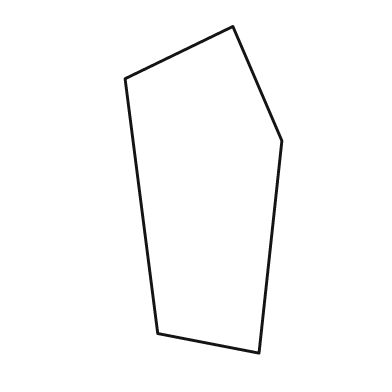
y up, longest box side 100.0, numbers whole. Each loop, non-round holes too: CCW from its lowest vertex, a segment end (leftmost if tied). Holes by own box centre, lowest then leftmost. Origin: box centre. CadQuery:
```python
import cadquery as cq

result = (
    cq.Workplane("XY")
    .moveTo(17.0, -50.0)
    .lineTo(24.0, 15.0)
    .lineTo(9.0, 50.0)
    .lineTo(-24.0, 34.0)
    .lineTo(-14.0, -44.0)
    .close()
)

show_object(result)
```